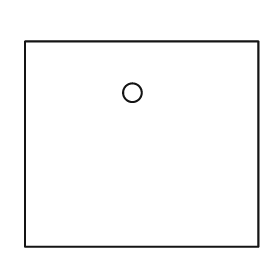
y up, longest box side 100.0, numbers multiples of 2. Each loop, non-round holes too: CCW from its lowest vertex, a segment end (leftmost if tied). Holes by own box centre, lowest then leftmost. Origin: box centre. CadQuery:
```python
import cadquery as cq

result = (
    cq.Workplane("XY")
    .moveTo(-50.0, -44.0)
    .lineTo(50.0, -44.0)
    .lineTo(50.0, 44.0)
    .lineTo(-50.0, 44.0)
    .close()
    .moveTo(-4.0, 22.0)
    .circle(4.0)
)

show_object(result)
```